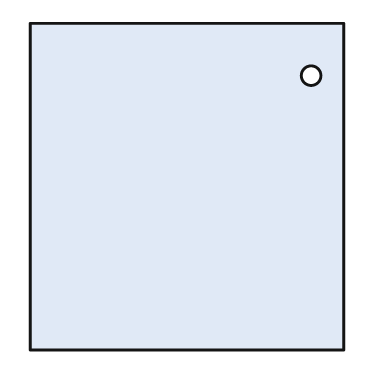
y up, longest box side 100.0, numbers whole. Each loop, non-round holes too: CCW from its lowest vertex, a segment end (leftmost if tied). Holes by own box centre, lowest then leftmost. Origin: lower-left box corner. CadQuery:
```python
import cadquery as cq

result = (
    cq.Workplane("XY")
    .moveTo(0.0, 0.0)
    .lineTo(96.0, 0.0)
    .lineTo(96.0, 100.0)
    .lineTo(0.0, 100.0)
    .close()
    .moveTo(86.0, 84.0)
    .circle(3.0)
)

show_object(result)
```